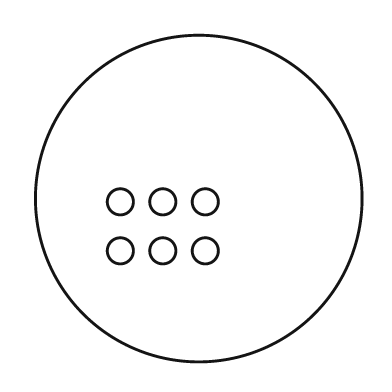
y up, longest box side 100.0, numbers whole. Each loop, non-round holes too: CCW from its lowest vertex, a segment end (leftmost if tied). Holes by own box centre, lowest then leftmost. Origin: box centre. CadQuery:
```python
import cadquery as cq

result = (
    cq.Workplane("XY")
    .moveTo(0.0, 0.0)
    .circle(50.0)
    .moveTo(-24.0, -16.0)
    .circle(4.0)
    .moveTo(-11.0, -16.0)
    .circle(4.0)
    .moveTo(2.0, -16.0)
    .circle(4.0)
    .moveTo(-24.0, -1.0)
    .circle(4.0)
    .moveTo(-11.0, -1.0)
    .circle(4.0)
    .moveTo(2.0, -1.0)
    .circle(4.0)
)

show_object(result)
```